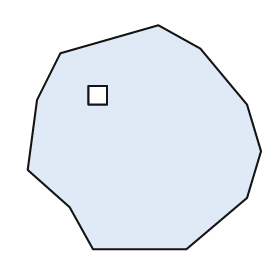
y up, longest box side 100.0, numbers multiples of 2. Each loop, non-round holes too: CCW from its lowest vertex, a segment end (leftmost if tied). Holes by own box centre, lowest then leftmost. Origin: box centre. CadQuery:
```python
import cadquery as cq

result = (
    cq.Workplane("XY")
    .moveTo(-22.0, -48.0)
    .lineTo(18.0, -48.0)
    .lineTo(44.0, -26.0)
    .lineTo(50.0, -6.0)
    .lineTo(44.0, 14.0)
    .lineTo(24.0, 38.0)
    .lineTo(6.0, 48.0)
    .lineTo(-36.0, 36.0)
    .lineTo(-46.0, 16.0)
    .lineTo(-50.0, -14.0)
    .lineTo(-32.0, -30.0)
    .close()
    .moveTo(-24.0, 14.0)
    .lineTo(-16.0, 14.0)
    .lineTo(-16.0, 22.0)
    .lineTo(-24.0, 22.0)
    .close()
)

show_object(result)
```